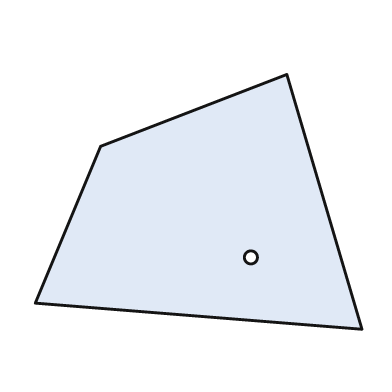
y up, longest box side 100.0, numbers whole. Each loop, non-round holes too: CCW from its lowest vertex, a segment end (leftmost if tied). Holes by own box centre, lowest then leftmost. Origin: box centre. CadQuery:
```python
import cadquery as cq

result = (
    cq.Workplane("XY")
    .moveTo(50.0, -39.0)
    .lineTo(27.0, 39.0)
    .lineTo(-30.0, 17.0)
    .lineTo(-50.0, -31.0)
    .close()
    .moveTo(16.0, -17.0)
    .circle(2.0)
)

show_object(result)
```